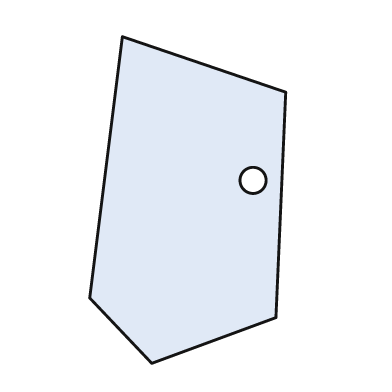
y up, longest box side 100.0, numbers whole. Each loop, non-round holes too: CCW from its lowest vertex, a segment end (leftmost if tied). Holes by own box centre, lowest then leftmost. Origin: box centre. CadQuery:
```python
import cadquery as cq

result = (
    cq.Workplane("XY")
    .moveTo(-11.0, -50.0)
    .lineTo(27.0, -36.0)
    .lineTo(30.0, 33.0)
    .lineTo(-20.0, 50.0)
    .lineTo(-30.0, -30.0)
    .close()
    .moveTo(20.0, 6.0)
    .circle(4.0)
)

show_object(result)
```